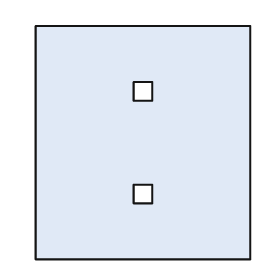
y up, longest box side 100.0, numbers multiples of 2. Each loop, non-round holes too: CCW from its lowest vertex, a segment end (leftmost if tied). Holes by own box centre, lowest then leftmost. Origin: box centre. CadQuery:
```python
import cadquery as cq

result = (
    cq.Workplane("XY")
    .moveTo(-46.0, -50.0)
    .lineTo(46.0, -50.0)
    .lineTo(46.0, 50.0)
    .lineTo(-46.0, 50.0)
    .close()
    .moveTo(-4.0, -26.0)
    .lineTo(4.0, -26.0)
    .lineTo(4.0, -18.0)
    .lineTo(-4.0, -18.0)
    .close()
    .moveTo(-4.0, 18.0)
    .lineTo(4.0, 18.0)
    .lineTo(4.0, 26.0)
    .lineTo(-4.0, 26.0)
    .close()
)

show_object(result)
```